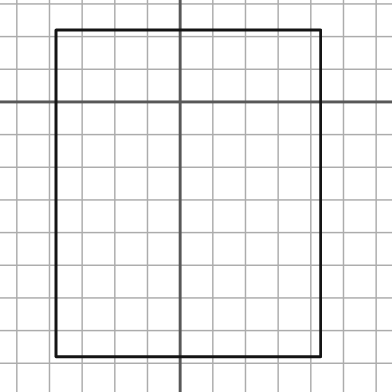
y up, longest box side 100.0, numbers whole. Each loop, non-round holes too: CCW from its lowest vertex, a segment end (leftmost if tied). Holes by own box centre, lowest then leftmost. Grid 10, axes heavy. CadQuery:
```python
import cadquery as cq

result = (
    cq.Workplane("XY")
    .moveTo(-38.0, -78.0)
    .lineTo(43.0, -78.0)
    .lineTo(43.0, 22.0)
    .lineTo(-38.0, 22.0)
    .close()
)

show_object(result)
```